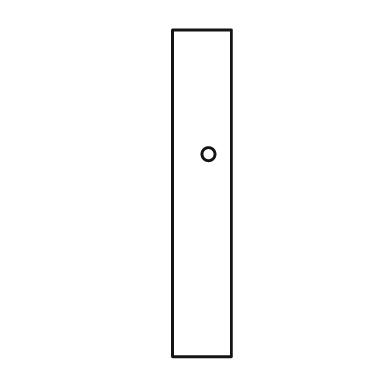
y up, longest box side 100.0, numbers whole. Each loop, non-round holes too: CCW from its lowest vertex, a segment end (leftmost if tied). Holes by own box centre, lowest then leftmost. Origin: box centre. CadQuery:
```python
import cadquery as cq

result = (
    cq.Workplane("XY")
    .moveTo(-9.0, -50.0)
    .lineTo(9.0, -50.0)
    .lineTo(9.0, 50.0)
    .lineTo(-9.0, 50.0)
    .close()
    .moveTo(2.0, 12.0)
    .circle(2.0)
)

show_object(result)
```